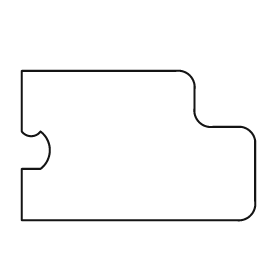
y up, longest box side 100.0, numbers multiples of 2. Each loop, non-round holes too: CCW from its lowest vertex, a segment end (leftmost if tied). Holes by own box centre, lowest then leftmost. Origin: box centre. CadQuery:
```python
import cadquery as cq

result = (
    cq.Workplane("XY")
    .moveTo(-50.0, -32.0)
    .lineTo(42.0, -32.0)
    .threePointArc((48.0, -30.0), (50.0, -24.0))
    .lineTo(50.0, 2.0)
    .threePointArc((48.0, 6.0), (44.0, 8.0))
    .lineTo(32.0, 8.0)
    .threePointArc((26.0, 10.0), (24.0, 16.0))
    .lineTo(24.0, 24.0)
    .threePointArc((22.0, 30.0), (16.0, 32.0))
    .lineTo(-50.0, 32.0)
    .lineTo(-50.0, 6.0)
    .threePointArc((-46.0, 4.0), (-42.0, 6.0))
    .threePointArc((-38.0, -2.0), (-42.0, -10.0))
    .lineTo(-50.0, -10.0)
    .close()
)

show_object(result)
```